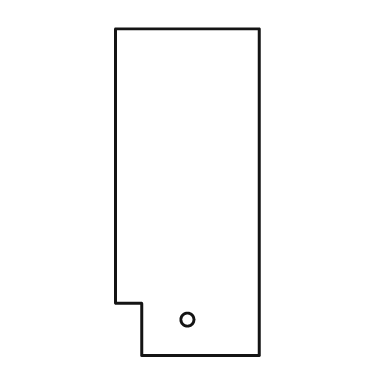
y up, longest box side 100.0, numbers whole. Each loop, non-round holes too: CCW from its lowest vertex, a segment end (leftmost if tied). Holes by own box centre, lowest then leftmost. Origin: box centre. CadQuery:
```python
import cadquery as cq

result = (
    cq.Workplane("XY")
    .moveTo(-14.0, -50.0)
    .lineTo(22.0, -50.0)
    .lineTo(22.0, 50.0)
    .lineTo(-22.0, 50.0)
    .lineTo(-22.0, -34.0)
    .lineTo(-14.0, -34.0)
    .close()
    .moveTo(0.0, -39.0)
    .circle(2.0)
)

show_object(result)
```